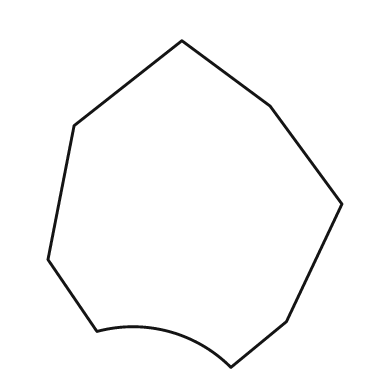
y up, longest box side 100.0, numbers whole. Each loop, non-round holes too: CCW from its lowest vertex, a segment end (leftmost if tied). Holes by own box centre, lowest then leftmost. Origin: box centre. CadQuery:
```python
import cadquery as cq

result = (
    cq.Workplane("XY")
    .moveTo(11.0, -50.0)
    .lineTo(28.0, -36.0)
    .lineTo(45.0, 0.0)
    .lineTo(23.0, 30.0)
    .lineTo(-4.0, 50.0)
    .lineTo(-37.0, 24.0)
    .lineTo(-45.0, -17.0)
    .lineTo(-30.0, -39.0)
    .threePointArc((-8.0, -39.0), (11.0, -50.0))
    .close()
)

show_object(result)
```